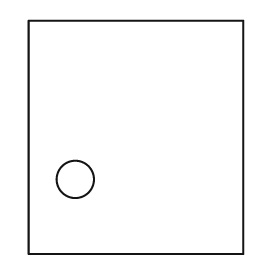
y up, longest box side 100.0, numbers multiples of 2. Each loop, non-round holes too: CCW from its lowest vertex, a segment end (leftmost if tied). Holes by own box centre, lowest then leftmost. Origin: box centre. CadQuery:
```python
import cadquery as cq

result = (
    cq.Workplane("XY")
    .moveTo(-46.0, -50.0)
    .lineTo(46.0, -50.0)
    .lineTo(46.0, 50.0)
    .lineTo(-46.0, 50.0)
    .close()
    .moveTo(-26.0, -18.0)
    .circle(8.0)
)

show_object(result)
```